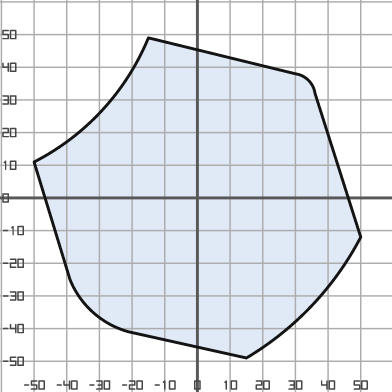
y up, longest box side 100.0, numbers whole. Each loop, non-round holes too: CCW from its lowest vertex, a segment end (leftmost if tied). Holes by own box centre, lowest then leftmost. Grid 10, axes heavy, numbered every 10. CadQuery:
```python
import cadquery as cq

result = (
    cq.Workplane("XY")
    .moveTo(15.0, -49.0)
    .threePointArc((35.0, -33.0), (50.0, -12.0))
    .lineTo(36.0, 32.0)
    .threePointArc((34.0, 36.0), (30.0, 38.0))
    .lineTo(-15.0, 49.0)
    .threePointArc((-29.0, 27.0), (-50.0, 11.0))
    .lineTo(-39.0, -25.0)
    .threePointArc((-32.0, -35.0), (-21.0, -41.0))
    .close()
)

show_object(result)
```